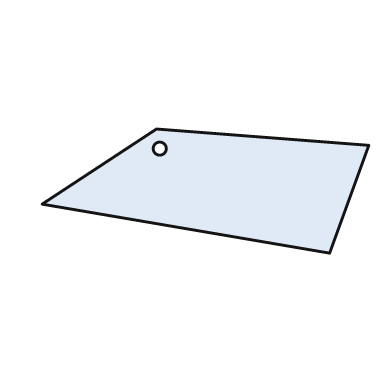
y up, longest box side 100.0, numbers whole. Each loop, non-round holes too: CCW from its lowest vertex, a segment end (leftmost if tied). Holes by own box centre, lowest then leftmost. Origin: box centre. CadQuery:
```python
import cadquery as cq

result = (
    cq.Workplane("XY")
    .moveTo(38.0, -19.0)
    .lineTo(50.0, 14.0)
    .lineTo(-15.0, 19.0)
    .lineTo(-50.0, -4.0)
    .close()
    .moveTo(-14.0, 13.0)
    .circle(2.0)
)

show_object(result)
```